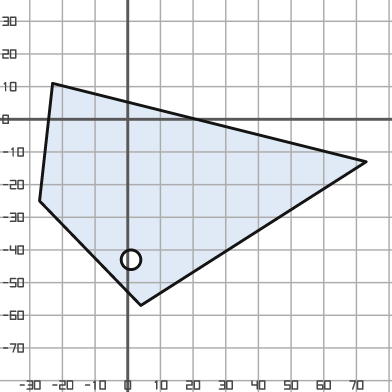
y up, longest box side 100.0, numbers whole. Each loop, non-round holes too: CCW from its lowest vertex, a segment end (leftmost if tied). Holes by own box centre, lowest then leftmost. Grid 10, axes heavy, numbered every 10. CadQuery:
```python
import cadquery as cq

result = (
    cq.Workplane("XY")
    .moveTo(4.0, -57.0)
    .lineTo(73.0, -13.0)
    .lineTo(-23.0, 11.0)
    .lineTo(-27.0, -25.0)
    .close()
    .moveTo(1.0, -43.0)
    .circle(3.0)
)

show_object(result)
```